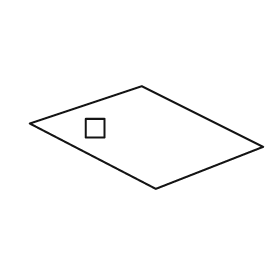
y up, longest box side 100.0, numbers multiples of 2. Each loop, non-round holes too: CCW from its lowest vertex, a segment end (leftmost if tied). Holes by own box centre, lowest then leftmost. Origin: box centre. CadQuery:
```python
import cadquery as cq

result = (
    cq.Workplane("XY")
    .moveTo(4.0, -22.0)
    .lineTo(50.0, -4.0)
    .lineTo(-2.0, 22.0)
    .lineTo(-50.0, 6.0)
    .close()
    .moveTo(-26.0, 0.0)
    .lineTo(-18.0, 0.0)
    .lineTo(-18.0, 8.0)
    .lineTo(-26.0, 8.0)
    .close()
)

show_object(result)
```